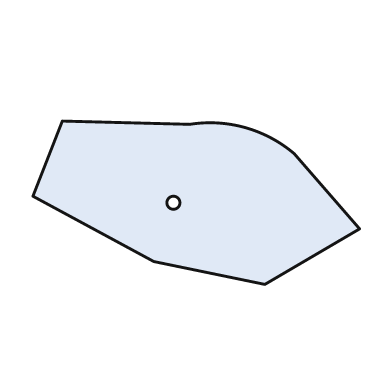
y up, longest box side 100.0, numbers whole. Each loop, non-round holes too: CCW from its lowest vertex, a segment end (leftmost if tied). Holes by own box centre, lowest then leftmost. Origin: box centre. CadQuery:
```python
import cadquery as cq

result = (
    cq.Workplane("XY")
    .moveTo(21.0, -25.0)
    .lineTo(50.0, -8.0)
    .lineTo(30.0, 15.0)
    .threePointArc((15.0, 23.0), (-2.0, 24.0))
    .lineTo(-41.0, 25.0)
    .lineTo(-50.0, 2.0)
    .lineTo(-13.0, -18.0)
    .close()
    .moveTo(-7.0, 0.0)
    .circle(2.0)
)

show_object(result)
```